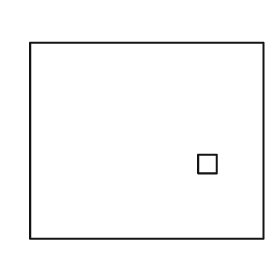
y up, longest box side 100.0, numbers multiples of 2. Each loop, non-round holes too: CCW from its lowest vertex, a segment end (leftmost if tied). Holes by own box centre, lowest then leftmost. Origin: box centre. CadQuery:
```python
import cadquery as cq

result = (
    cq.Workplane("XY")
    .moveTo(-50.0, -42.0)
    .lineTo(50.0, -42.0)
    .lineTo(50.0, 42.0)
    .lineTo(-50.0, 42.0)
    .close()
    .moveTo(22.0, -14.0)
    .lineTo(30.0, -14.0)
    .lineTo(30.0, -6.0)
    .lineTo(22.0, -6.0)
    .close()
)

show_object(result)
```